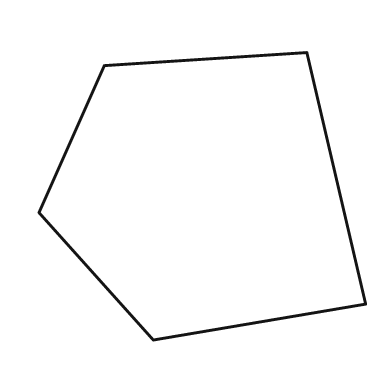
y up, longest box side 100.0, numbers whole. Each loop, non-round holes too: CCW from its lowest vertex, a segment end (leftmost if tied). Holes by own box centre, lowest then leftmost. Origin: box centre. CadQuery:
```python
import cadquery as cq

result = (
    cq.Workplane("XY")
    .moveTo(-15.0, -44.0)
    .lineTo(50.0, -33.0)
    .lineTo(32.0, 44.0)
    .lineTo(-30.0, 40.0)
    .lineTo(-50.0, -5.0)
    .close()
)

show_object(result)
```